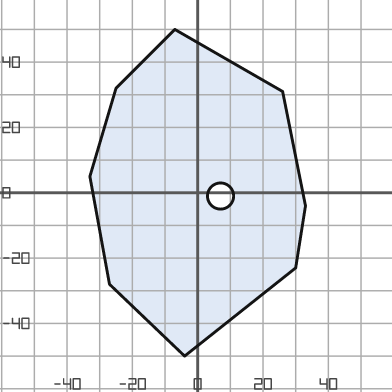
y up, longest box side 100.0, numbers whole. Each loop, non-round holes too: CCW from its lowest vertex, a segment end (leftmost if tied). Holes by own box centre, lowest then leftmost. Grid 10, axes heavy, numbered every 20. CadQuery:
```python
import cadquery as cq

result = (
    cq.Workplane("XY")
    .moveTo(-4.0, -50.0)
    .lineTo(30.0, -23.0)
    .lineTo(33.0, -4.0)
    .lineTo(26.0, 31.0)
    .lineTo(-7.0, 50.0)
    .lineTo(-25.0, 32.0)
    .lineTo(-33.0, 5.0)
    .lineTo(-27.0, -28.0)
    .close()
    .moveTo(7.0, -1.0)
    .circle(4.0)
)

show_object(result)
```